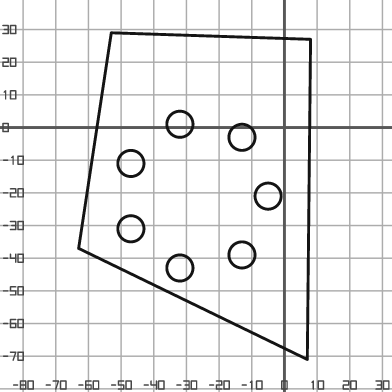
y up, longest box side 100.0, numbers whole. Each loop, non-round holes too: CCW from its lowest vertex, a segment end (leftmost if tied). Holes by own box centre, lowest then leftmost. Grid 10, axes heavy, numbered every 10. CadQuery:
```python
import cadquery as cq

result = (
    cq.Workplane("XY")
    .moveTo(7.0, -71.0)
    .lineTo(8.0, 27.0)
    .lineTo(-53.0, 29.0)
    .lineTo(-63.0, -37.0)
    .close()
    .moveTo(-32.0, -43.0)
    .circle(4.0)
    .moveTo(-13.0, -39.0)
    .circle(4.0)
    .moveTo(-47.0, -31.0)
    .circle(4.0)
    .moveTo(-5.0, -21.0)
    .circle(4.0)
    .moveTo(-47.0, -11.0)
    .circle(4.0)
    .moveTo(-13.0, -3.0)
    .circle(4.0)
    .moveTo(-32.0, 1.0)
    .circle(4.0)
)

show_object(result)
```